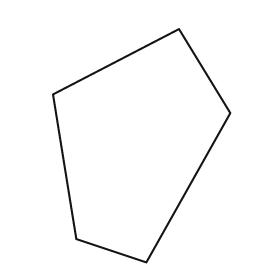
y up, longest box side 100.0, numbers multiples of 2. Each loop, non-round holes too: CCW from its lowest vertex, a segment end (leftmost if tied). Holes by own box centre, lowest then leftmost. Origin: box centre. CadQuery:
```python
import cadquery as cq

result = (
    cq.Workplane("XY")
    .moveTo(2.0, -50.0)
    .lineTo(38.0, 14.0)
    .lineTo(16.0, 50.0)
    .lineTo(-38.0, 22.0)
    .lineTo(-28.0, -40.0)
    .close()
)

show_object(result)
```